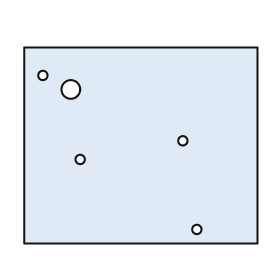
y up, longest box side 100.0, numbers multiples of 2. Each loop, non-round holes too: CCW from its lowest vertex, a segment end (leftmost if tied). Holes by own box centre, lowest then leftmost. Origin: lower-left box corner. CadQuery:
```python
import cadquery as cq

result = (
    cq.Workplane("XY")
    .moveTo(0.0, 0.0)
    .lineTo(100.0, 0.0)
    .lineTo(100.0, 84.0)
    .lineTo(0.0, 84.0)
    .close()
    .moveTo(74.0, 6.0)
    .circle(2.0)
    .moveTo(24.0, 36.0)
    .circle(2.0)
    .moveTo(68.0, 44.0)
    .circle(2.0)
    .moveTo(20.0, 66.0)
    .circle(4.0)
    .moveTo(8.0, 72.0)
    .circle(2.0)
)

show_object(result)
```